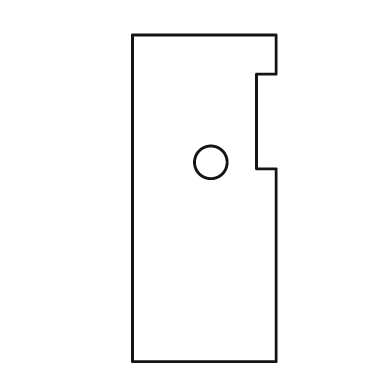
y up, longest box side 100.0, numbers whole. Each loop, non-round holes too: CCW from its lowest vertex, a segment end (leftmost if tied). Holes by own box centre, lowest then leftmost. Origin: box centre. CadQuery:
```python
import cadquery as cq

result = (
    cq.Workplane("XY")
    .moveTo(-22.0, -50.0)
    .lineTo(22.0, -50.0)
    .lineTo(22.0, 9.0)
    .lineTo(16.0, 9.0)
    .lineTo(16.0, 38.0)
    .lineTo(22.0, 38.0)
    .lineTo(22.0, 50.0)
    .lineTo(-22.0, 50.0)
    .close()
    .moveTo(2.0, 11.0)
    .circle(5.0)
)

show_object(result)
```